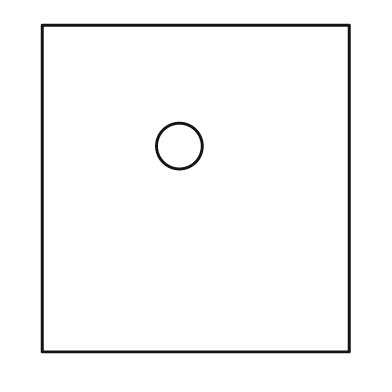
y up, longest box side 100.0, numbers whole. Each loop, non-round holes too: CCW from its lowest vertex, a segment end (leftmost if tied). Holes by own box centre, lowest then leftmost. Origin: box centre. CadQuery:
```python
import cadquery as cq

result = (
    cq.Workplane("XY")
    .moveTo(-47.0, -50.0)
    .lineTo(47.0, -50.0)
    .lineTo(47.0, 50.0)
    .lineTo(-47.0, 50.0)
    .close()
    .moveTo(-5.0, 13.0)
    .circle(7.0)
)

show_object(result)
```